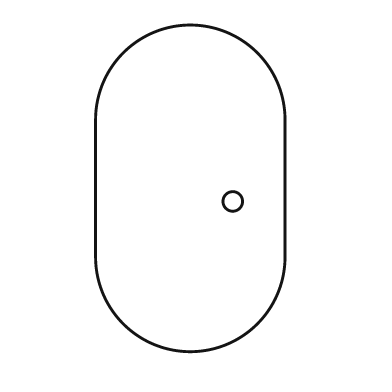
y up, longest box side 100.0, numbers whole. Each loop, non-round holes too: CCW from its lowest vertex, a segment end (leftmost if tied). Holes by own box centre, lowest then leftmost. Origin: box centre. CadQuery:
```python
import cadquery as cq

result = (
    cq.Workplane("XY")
    .moveTo(-29.0, -21.0)
    .threePointArc((0.0, -50.0), (29.0, -21.0))
    .lineTo(29.0, 21.0)
    .threePointArc((0.0, 50.0), (-29.0, 21.0))
    .close()
    .moveTo(13.0, -4.0)
    .circle(3.0)
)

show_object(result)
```